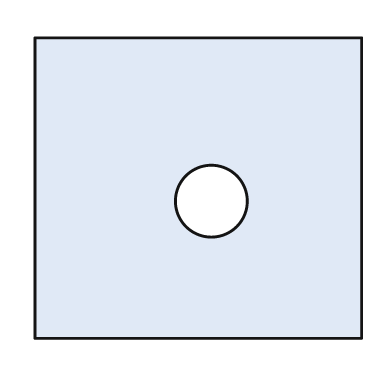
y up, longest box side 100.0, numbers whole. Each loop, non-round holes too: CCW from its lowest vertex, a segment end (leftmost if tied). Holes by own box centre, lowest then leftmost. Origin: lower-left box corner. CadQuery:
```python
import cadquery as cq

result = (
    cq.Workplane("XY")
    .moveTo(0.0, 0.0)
    .lineTo(100.0, 0.0)
    .lineTo(100.0, 92.0)
    .lineTo(0.0, 92.0)
    .close()
    .moveTo(54.0, 42.0)
    .circle(11.0)
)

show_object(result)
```